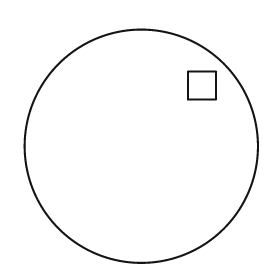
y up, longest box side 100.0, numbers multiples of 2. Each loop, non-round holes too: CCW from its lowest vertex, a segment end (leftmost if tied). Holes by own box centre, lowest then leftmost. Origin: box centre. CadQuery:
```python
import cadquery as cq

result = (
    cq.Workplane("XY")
    .moveTo(0.0, 0.0)
    .circle(50.0)
    .moveTo(20.0, 20.0)
    .lineTo(32.0, 20.0)
    .lineTo(32.0, 32.0)
    .lineTo(20.0, 32.0)
    .close()
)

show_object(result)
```